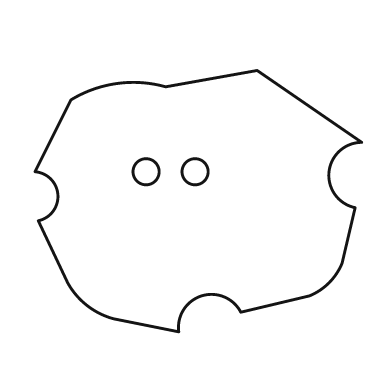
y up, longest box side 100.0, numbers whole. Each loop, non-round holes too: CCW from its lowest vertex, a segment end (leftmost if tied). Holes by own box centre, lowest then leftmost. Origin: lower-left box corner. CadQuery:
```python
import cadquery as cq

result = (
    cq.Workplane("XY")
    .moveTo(44.0, 0.0)
    .threePointArc((51.0, 11.0), (63.0, 6.0))
    .lineTo(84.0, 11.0)
    .threePointArc((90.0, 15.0), (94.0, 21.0))
    .lineTo(98.0, 38.0)
    .threePointArc((90.0, 49.0), (100.0, 58.0))
    .lineTo(68.0, 80.0)
    .lineTo(40.0, 75.0)
    .threePointArc((25.0, 76.0), (11.0, 71.0))
    .lineTo(0.0, 49.0)
    .threePointArc((7.0, 42.0), (1.0, 34.0))
    .lineTo(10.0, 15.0)
    .threePointArc((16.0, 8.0), (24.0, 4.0))
    .close()
    .moveTo(34.0, 49.0)
    .circle(4.0)
    .moveTo(49.0, 49.0)
    .circle(4.0)
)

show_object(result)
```